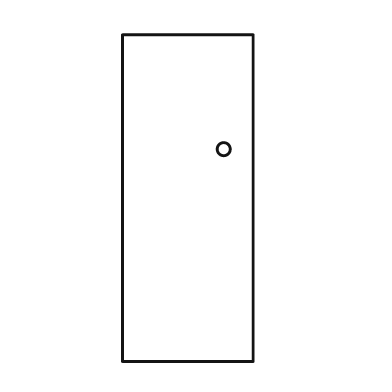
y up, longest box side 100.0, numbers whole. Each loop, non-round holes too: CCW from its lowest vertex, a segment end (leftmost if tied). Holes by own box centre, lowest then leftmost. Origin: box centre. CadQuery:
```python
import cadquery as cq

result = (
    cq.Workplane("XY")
    .moveTo(-20.0, -50.0)
    .lineTo(20.0, -50.0)
    .lineTo(20.0, 50.0)
    .lineTo(-20.0, 50.0)
    .close()
    .moveTo(11.0, 15.0)
    .circle(2.0)
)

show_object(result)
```